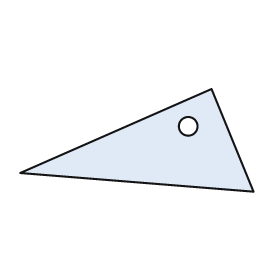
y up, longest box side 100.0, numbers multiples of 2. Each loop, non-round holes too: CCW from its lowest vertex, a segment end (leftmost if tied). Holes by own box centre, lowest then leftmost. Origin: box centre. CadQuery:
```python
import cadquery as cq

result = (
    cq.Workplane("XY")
    .moveTo(50.0, -22.0)
    .lineTo(32.0, 22.0)
    .lineTo(-50.0, -14.0)
    .close()
    .moveTo(22.0, 6.0)
    .circle(4.0)
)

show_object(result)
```